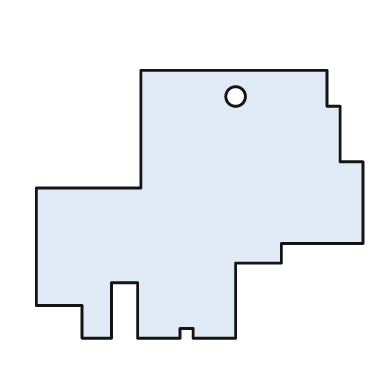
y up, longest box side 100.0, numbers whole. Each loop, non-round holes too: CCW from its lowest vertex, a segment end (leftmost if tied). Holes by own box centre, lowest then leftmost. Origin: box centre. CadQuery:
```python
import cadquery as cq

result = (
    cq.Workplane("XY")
    .moveTo(-36.0, -41.0)
    .lineTo(-27.0, -41.0)
    .lineTo(-27.0, -24.0)
    .lineTo(-19.0, -24.0)
    .lineTo(-19.0, -41.0)
    .lineTo(-6.0, -41.0)
    .lineTo(-6.0, -38.0)
    .lineTo(-2.0, -38.0)
    .lineTo(-2.0, -41.0)
    .lineTo(11.0, -41.0)
    .lineTo(11.0, -18.0)
    .lineTo(25.0, -18.0)
    .lineTo(25.0, -12.0)
    .lineTo(50.0, -12.0)
    .lineTo(50.0, 13.0)
    .lineTo(43.0, 13.0)
    .lineTo(43.0, 30.0)
    .lineTo(39.0, 30.0)
    .lineTo(39.0, 41.0)
    .lineTo(-18.0, 41.0)
    .lineTo(-18.0, 5.0)
    .lineTo(-50.0, 5.0)
    .lineTo(-50.0, -31.0)
    .lineTo(-36.0, -31.0)
    .close()
    .moveTo(11.0, 33.0)
    .circle(3.0)
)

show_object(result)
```